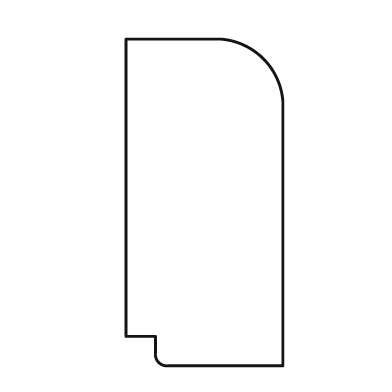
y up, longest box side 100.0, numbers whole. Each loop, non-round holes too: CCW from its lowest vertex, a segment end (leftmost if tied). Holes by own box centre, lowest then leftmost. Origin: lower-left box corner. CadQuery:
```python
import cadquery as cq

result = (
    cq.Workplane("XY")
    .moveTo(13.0, 0.0)
    .lineTo(48.0, 0.0)
    .lineTo(48.0, 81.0)
    .threePointArc((42.0, 94.0), (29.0, 100.0))
    .lineTo(0.0, 100.0)
    .lineTo(0.0, 9.0)
    .lineTo(9.0, 9.0)
    .lineTo(9.0, 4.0)
    .threePointArc((10.0, 1.0), (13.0, 0.0))
    .close()
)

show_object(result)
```